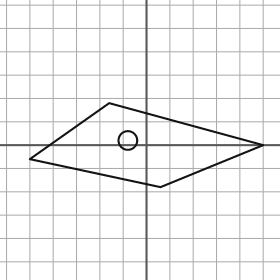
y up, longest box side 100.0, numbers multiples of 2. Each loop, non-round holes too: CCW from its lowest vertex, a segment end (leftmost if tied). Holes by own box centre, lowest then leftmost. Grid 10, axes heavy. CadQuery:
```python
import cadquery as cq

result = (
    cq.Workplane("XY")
    .moveTo(6.0, -18.0)
    .lineTo(50.0, 0.0)
    .lineTo(-16.0, 18.0)
    .lineTo(-50.0, -6.0)
    .close()
    .moveTo(-8.0, 2.0)
    .circle(4.0)
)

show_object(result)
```